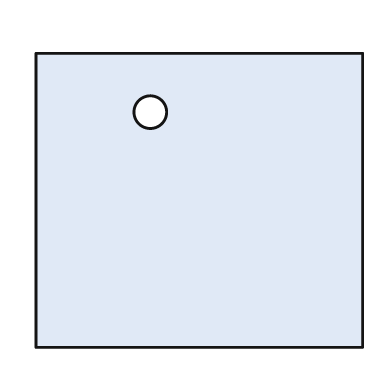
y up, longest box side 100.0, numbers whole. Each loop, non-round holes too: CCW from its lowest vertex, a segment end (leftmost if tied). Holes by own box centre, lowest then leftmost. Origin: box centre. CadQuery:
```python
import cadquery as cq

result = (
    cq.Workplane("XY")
    .moveTo(-50.0, -45.0)
    .lineTo(50.0, -45.0)
    .lineTo(50.0, 45.0)
    .lineTo(-50.0, 45.0)
    .close()
    .moveTo(-15.0, 27.0)
    .circle(5.0)
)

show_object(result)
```